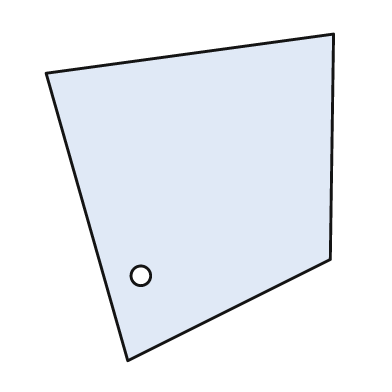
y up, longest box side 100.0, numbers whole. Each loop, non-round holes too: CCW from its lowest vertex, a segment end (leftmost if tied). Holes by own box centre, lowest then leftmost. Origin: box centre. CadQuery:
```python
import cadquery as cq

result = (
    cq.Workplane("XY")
    .moveTo(-19.0, -50.0)
    .lineTo(43.0, -19.0)
    .lineTo(44.0, 50.0)
    .lineTo(-44.0, 38.0)
    .close()
    .moveTo(-15.0, -24.0)
    .circle(3.0)
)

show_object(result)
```